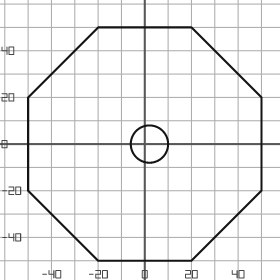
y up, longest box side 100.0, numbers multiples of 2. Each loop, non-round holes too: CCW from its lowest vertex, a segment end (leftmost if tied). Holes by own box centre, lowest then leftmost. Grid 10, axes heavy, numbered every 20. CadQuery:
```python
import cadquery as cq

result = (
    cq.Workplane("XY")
    .moveTo(-20.0, -50.0)
    .lineTo(20.0, -50.0)
    .lineTo(50.0, -20.0)
    .lineTo(50.0, 20.0)
    .lineTo(20.0, 50.0)
    .lineTo(-20.0, 50.0)
    .lineTo(-50.0, 20.0)
    .lineTo(-50.0, -20.0)
    .close()
    .moveTo(2.0, 0.0)
    .circle(8.0)
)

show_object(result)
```